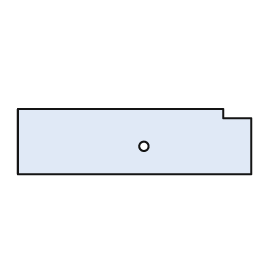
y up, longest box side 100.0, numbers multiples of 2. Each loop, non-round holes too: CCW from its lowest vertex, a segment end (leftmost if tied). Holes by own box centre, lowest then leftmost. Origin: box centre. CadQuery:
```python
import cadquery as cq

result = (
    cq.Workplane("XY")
    .moveTo(-50.0, -14.0)
    .lineTo(50.0, -14.0)
    .lineTo(50.0, 10.0)
    .lineTo(38.0, 10.0)
    .lineTo(38.0, 14.0)
    .lineTo(-50.0, 14.0)
    .close()
    .moveTo(4.0, -2.0)
    .circle(2.0)
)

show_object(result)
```